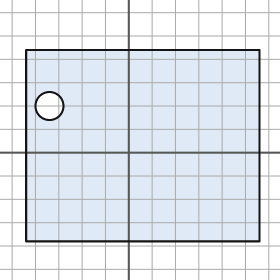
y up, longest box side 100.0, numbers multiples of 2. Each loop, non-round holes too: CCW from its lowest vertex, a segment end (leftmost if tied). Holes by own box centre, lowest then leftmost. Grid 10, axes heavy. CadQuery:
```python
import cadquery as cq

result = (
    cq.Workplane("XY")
    .moveTo(-44.0, -38.0)
    .lineTo(56.0, -38.0)
    .lineTo(56.0, 44.0)
    .lineTo(-44.0, 44.0)
    .close()
    .moveTo(-34.0, 20.0)
    .circle(6.0)
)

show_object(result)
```